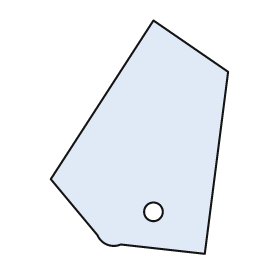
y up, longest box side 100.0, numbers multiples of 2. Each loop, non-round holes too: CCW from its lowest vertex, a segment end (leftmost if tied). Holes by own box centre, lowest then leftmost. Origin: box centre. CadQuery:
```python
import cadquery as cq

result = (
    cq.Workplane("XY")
    .moveTo(28.0, -50.0)
    .lineTo(38.0, 28.0)
    .lineTo(6.0, 50.0)
    .lineTo(-38.0, -18.0)
    .lineTo(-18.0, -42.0)
    .threePointArc((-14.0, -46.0), (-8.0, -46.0))
    .close()
    .moveTo(6.0, -32.0)
    .circle(4.0)
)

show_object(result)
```